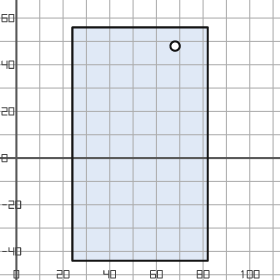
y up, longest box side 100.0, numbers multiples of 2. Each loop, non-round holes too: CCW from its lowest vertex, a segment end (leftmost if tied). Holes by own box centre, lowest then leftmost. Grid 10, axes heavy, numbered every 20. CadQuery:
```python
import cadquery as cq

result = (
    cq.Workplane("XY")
    .moveTo(24.0, -44.0)
    .lineTo(82.0, -44.0)
    .lineTo(82.0, 56.0)
    .lineTo(24.0, 56.0)
    .close()
    .moveTo(68.0, 48.0)
    .circle(2.0)
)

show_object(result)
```